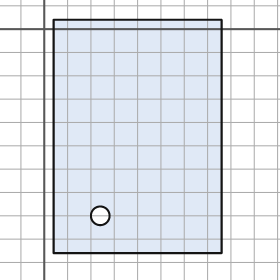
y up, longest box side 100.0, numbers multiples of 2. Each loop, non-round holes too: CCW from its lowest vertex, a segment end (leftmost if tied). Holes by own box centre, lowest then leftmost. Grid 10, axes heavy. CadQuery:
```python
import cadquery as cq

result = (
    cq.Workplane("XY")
    .moveTo(4.0, -96.0)
    .lineTo(76.0, -96.0)
    .lineTo(76.0, 4.0)
    .lineTo(4.0, 4.0)
    .close()
    .moveTo(24.0, -80.0)
    .circle(4.0)
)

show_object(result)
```